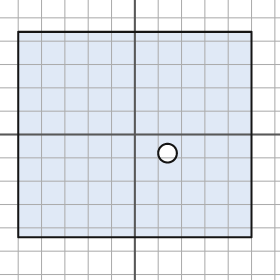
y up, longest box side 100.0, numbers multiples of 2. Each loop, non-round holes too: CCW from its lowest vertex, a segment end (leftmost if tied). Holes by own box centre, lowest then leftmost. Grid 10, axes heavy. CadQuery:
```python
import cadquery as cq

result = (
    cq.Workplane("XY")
    .moveTo(-50.0, -44.0)
    .lineTo(50.0, -44.0)
    .lineTo(50.0, 44.0)
    .lineTo(-50.0, 44.0)
    .close()
    .moveTo(14.0, -8.0)
    .circle(4.0)
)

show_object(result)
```